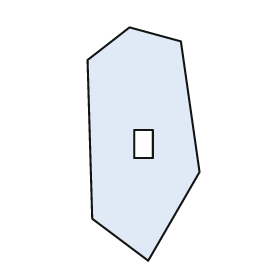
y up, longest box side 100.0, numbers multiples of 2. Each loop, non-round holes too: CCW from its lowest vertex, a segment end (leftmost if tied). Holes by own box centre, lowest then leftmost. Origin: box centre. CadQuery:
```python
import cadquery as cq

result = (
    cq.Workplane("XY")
    .moveTo(2.0, -50.0)
    .lineTo(24.0, -12.0)
    .lineTo(16.0, 44.0)
    .lineTo(-6.0, 50.0)
    .lineTo(-24.0, 36.0)
    .lineTo(-22.0, -32.0)
    .close()
    .moveTo(-4.0, -6.0)
    .lineTo(4.0, -6.0)
    .lineTo(4.0, 6.0)
    .lineTo(-4.0, 6.0)
    .close()
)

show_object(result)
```